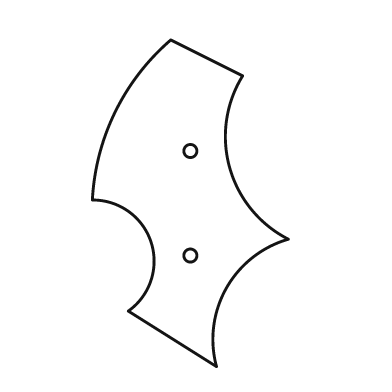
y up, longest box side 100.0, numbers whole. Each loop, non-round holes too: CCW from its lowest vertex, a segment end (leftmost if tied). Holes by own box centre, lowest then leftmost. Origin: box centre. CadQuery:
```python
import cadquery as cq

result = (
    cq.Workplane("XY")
    .moveTo(8.0, -50.0)
    .threePointArc((11.0, -26.0), (30.0, -11.0))
    .threePointArc((12.0, 11.0), (16.0, 39.0))
    .lineTo(-6.0, 50.0)
    .threePointArc((-23.0, 28.0), (-30.0, 1.0))
    .threePointArc((-12.0, -12.0), (-19.0, -33.0))
    .close()
    .moveTo(0.0, -16.0)
    .circle(2.0)
    .moveTo(0.0, 16.0)
    .circle(2.0)
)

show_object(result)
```